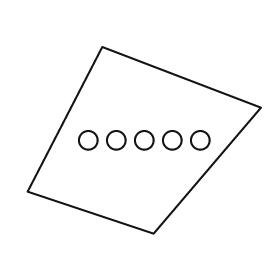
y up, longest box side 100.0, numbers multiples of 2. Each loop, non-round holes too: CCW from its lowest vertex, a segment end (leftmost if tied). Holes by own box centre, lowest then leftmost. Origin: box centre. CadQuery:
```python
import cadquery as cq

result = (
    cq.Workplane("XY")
    .moveTo(4.0, -40.0)
    .lineTo(50.0, 14.0)
    .lineTo(-18.0, 40.0)
    .lineTo(-50.0, -22.0)
    .close()
    .moveTo(-24.0, 0.0)
    .circle(4.0)
    .moveTo(-12.0, 0.0)
    .circle(4.0)
    .moveTo(0.0, 0.0)
    .circle(4.0)
    .moveTo(12.0, 0.0)
    .circle(4.0)
    .moveTo(24.0, 0.0)
    .circle(4.0)
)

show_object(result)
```